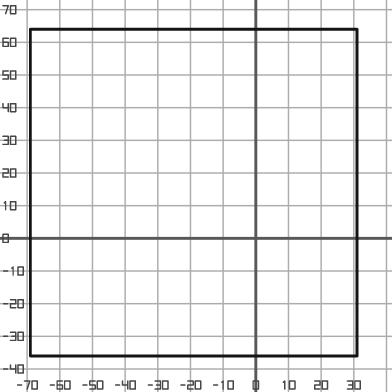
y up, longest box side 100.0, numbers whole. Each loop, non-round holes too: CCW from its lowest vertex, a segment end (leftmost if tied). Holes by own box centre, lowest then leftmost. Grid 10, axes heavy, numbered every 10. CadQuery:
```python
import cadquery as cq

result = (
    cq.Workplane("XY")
    .moveTo(-69.0, -36.0)
    .lineTo(31.0, -36.0)
    .lineTo(31.0, 64.0)
    .lineTo(-69.0, 64.0)
    .close()
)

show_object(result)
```